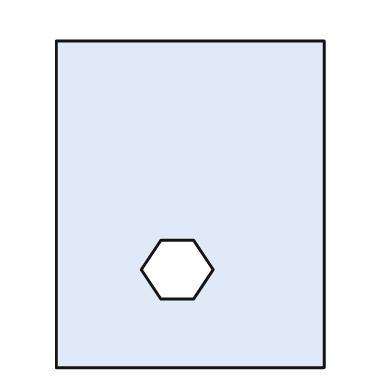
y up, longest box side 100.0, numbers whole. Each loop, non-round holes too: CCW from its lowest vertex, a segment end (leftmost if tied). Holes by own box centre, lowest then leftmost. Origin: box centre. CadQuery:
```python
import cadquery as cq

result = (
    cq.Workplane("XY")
    .moveTo(-41.0, -50.0)
    .lineTo(41.0, -50.0)
    .lineTo(41.0, 50.0)
    .lineTo(-41.0, 50.0)
    .close()
    .moveTo(-9.0, -29.0)
    .lineTo(1.0, -29.0)
    .lineTo(7.0, -20.0)
    .lineTo(1.0, -11.0)
    .lineTo(-9.0, -11.0)
    .lineTo(-15.0, -20.0)
    .close()
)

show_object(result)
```